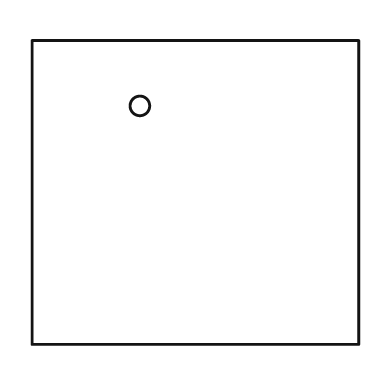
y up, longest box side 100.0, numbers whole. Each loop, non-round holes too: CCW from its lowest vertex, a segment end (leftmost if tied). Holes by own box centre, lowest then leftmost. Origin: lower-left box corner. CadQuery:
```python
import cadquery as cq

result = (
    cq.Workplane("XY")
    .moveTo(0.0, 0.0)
    .lineTo(100.0, 0.0)
    .lineTo(100.0, 93.0)
    .lineTo(0.0, 93.0)
    .close()
    .moveTo(33.0, 73.0)
    .circle(3.0)
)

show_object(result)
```